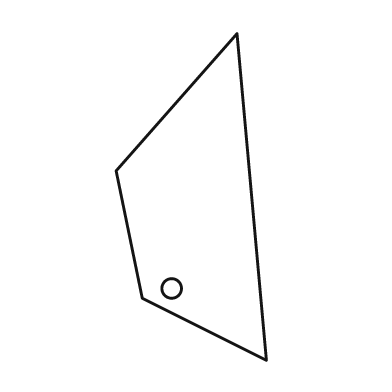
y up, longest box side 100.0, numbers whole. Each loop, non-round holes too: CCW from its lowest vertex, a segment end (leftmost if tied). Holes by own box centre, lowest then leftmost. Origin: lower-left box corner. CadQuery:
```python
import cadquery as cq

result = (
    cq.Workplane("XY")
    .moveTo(46.0, 0.0)
    .lineTo(37.0, 100.0)
    .lineTo(0.0, 58.0)
    .lineTo(8.0, 19.0)
    .close()
    .moveTo(17.0, 22.0)
    .circle(3.0)
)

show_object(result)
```